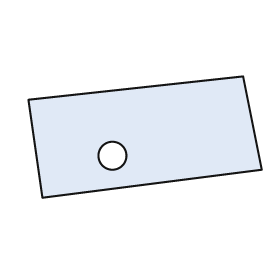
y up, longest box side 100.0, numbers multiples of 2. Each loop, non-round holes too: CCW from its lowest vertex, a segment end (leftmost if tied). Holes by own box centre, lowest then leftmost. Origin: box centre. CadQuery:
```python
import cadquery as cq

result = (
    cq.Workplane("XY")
    .moveTo(-44.0, -26.0)
    .lineTo(50.0, -14.0)
    .lineTo(42.0, 26.0)
    .lineTo(-50.0, 16.0)
    .close()
    .moveTo(-14.0, -8.0)
    .circle(6.0)
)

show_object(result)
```